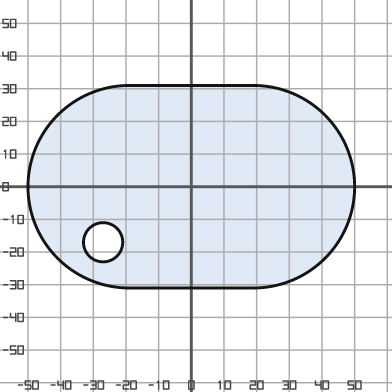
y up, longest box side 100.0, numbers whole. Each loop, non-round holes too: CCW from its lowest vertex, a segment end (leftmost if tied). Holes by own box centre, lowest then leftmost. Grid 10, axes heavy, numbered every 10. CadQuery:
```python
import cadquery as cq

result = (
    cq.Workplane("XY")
    .moveTo(-19.0, -31.0)
    .lineTo(19.0, -31.0)
    .threePointArc((50.0, 0.0), (19.0, 31.0))
    .lineTo(-19.0, 31.0)
    .threePointArc((-50.0, 0.0), (-19.0, -31.0))
    .close()
    .moveTo(-27.0, -17.0)
    .circle(6.0)
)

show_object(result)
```